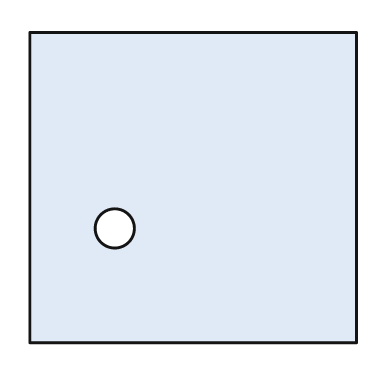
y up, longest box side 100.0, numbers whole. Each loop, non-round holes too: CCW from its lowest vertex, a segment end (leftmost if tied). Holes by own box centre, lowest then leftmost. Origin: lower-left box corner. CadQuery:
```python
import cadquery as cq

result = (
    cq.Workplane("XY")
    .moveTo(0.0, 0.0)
    .lineTo(100.0, 0.0)
    .lineTo(100.0, 95.0)
    .lineTo(0.0, 95.0)
    .close()
    .moveTo(26.0, 35.0)
    .circle(6.0)
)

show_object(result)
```